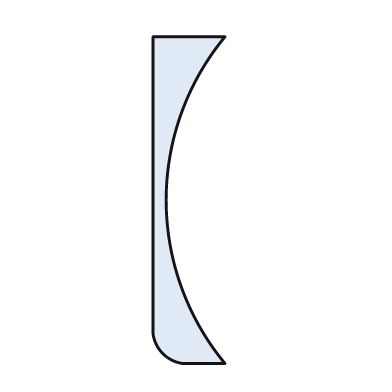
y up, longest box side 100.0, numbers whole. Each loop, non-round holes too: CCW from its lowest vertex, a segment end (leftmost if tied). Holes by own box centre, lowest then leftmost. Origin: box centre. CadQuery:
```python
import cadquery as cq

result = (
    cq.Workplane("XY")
    .moveTo(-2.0, -50.0)
    .lineTo(11.0, -50.0)
    .threePointArc((-7.0, 0.0), (11.0, 50.0))
    .lineTo(-11.0, 50.0)
    .lineTo(-11.0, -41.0)
    .threePointArc((-8.0, -47.0), (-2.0, -50.0))
    .close()
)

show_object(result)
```